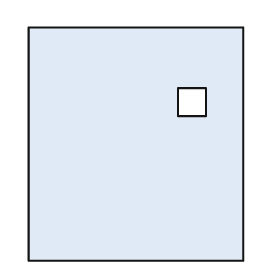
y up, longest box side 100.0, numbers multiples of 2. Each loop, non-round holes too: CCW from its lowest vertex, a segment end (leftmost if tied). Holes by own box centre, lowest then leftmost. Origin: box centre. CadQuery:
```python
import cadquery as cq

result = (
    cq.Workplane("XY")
    .moveTo(-46.0, -50.0)
    .lineTo(46.0, -50.0)
    .lineTo(46.0, 50.0)
    .lineTo(-46.0, 50.0)
    .close()
    .moveTo(18.0, 12.0)
    .lineTo(30.0, 12.0)
    .lineTo(30.0, 24.0)
    .lineTo(18.0, 24.0)
    .close()
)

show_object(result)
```